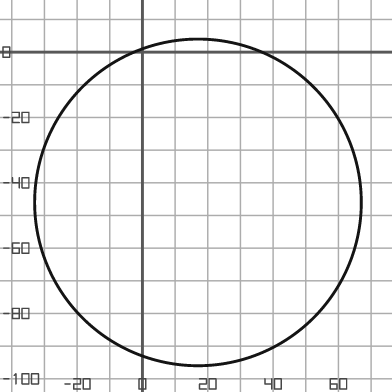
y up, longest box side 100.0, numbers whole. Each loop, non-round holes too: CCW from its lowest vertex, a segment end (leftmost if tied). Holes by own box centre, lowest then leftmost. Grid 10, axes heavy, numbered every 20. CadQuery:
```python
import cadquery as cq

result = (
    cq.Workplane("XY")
    .moveTo(17.0, -46.0)
    .circle(50.0)
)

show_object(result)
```